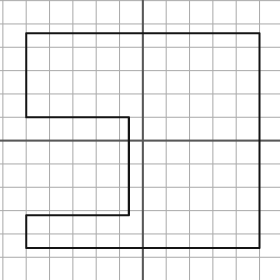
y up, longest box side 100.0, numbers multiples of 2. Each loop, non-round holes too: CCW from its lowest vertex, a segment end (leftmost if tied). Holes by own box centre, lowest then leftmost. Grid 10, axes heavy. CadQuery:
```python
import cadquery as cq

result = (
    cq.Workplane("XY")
    .moveTo(-50.0, -46.0)
    .lineTo(50.0, -46.0)
    .lineTo(50.0, 46.0)
    .lineTo(-50.0, 46.0)
    .lineTo(-50.0, 10.0)
    .lineTo(-6.0, 10.0)
    .lineTo(-6.0, -32.0)
    .lineTo(-50.0, -32.0)
    .close()
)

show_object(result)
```